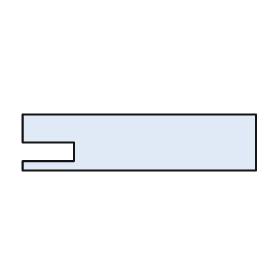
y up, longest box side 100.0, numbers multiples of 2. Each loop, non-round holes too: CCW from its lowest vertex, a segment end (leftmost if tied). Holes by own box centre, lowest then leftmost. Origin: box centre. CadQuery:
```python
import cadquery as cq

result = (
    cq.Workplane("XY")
    .moveTo(-50.0, -12.0)
    .lineTo(50.0, -12.0)
    .lineTo(50.0, 12.0)
    .lineTo(-50.0, 12.0)
    .lineTo(-50.0, 0.0)
    .lineTo(-28.0, 0.0)
    .lineTo(-28.0, -8.0)
    .lineTo(-50.0, -8.0)
    .close()
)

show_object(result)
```